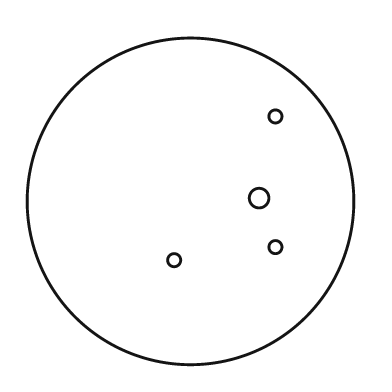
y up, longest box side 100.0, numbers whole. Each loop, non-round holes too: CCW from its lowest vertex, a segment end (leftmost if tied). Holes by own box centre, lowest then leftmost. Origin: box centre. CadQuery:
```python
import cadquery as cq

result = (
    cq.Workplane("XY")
    .moveTo(0.0, 0.0)
    .circle(50.0)
    .moveTo(-5.0, -18.0)
    .circle(2.0)
    .moveTo(26.0, -14.0)
    .circle(2.0)
    .moveTo(21.0, 1.0)
    .circle(3.0)
    .moveTo(26.0, 26.0)
    .circle(2.0)
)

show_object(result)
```